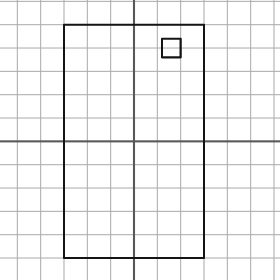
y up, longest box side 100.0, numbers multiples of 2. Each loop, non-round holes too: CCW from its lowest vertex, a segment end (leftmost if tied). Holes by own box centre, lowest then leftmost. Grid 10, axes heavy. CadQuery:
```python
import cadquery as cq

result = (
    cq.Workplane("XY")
    .moveTo(-30.0, -50.0)
    .lineTo(30.0, -50.0)
    .lineTo(30.0, 50.0)
    .lineTo(-30.0, 50.0)
    .close()
    .moveTo(12.0, 36.0)
    .lineTo(20.0, 36.0)
    .lineTo(20.0, 44.0)
    .lineTo(12.0, 44.0)
    .close()
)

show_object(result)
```